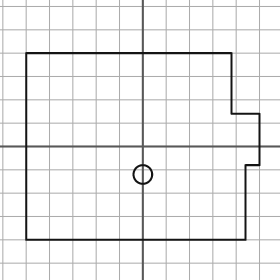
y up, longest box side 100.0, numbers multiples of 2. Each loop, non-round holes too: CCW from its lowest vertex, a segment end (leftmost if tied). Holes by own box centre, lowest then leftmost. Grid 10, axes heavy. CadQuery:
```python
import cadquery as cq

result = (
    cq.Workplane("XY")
    .moveTo(-50.0, -40.0)
    .lineTo(44.0, -40.0)
    .lineTo(44.0, -8.0)
    .lineTo(50.0, -8.0)
    .lineTo(50.0, 14.0)
    .lineTo(38.0, 14.0)
    .lineTo(38.0, 40.0)
    .lineTo(-50.0, 40.0)
    .close()
    .moveTo(0.0, -12.0)
    .circle(4.0)
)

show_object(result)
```